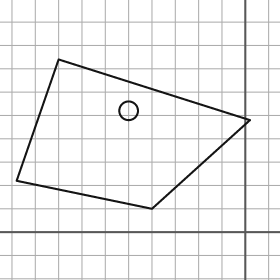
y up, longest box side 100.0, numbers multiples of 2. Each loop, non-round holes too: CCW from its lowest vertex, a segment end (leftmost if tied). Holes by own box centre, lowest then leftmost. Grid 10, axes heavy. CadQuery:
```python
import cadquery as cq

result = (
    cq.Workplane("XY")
    .moveTo(-40.0, 10.0)
    .lineTo(2.0, 48.0)
    .lineTo(-80.0, 74.0)
    .lineTo(-98.0, 22.0)
    .close()
    .moveTo(-50.0, 52.0)
    .circle(4.0)
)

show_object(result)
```